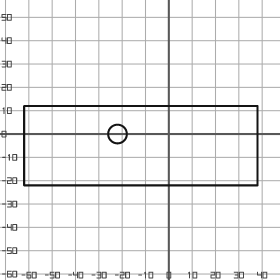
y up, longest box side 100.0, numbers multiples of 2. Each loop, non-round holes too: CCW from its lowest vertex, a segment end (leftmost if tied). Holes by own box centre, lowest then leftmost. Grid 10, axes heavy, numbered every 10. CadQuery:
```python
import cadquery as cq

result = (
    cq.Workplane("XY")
    .moveTo(-62.0, -22.0)
    .lineTo(38.0, -22.0)
    .lineTo(38.0, 12.0)
    .lineTo(-62.0, 12.0)
    .close()
    .moveTo(-22.0, 0.0)
    .circle(4.0)
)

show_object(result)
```